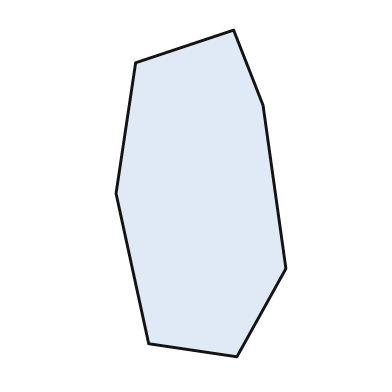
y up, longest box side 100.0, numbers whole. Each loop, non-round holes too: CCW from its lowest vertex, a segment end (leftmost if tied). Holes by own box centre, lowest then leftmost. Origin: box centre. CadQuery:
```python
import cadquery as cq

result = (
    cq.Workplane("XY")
    .moveTo(11.0, -50.0)
    .lineTo(26.0, -23.0)
    .lineTo(19.0, 27.0)
    .lineTo(10.0, 50.0)
    .lineTo(-20.0, 40.0)
    .lineTo(-26.0, 0.0)
    .lineTo(-16.0, -46.0)
    .close()
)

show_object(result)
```